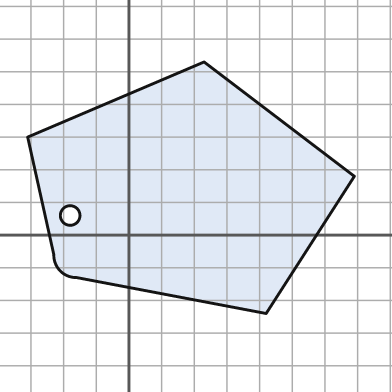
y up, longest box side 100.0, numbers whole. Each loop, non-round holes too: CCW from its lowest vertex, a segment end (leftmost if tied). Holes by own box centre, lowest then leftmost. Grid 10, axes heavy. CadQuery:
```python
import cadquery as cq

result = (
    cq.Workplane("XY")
    .moveTo(42.0, -24.0)
    .lineTo(69.0, 18.0)
    .lineTo(23.0, 53.0)
    .lineTo(-31.0, 30.0)
    .lineTo(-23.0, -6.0)
    .threePointArc((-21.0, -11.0), (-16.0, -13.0))
    .close()
    .moveTo(-18.0, 6.0)
    .circle(3.0)
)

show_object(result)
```